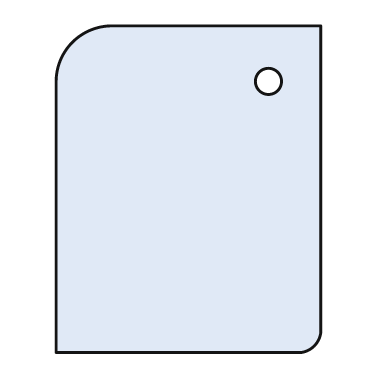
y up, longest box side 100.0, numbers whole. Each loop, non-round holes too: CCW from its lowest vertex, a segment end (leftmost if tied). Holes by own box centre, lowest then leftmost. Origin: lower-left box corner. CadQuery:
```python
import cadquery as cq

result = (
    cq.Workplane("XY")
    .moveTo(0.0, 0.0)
    .lineTo(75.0, 0.0)
    .threePointArc((79.0, 2.0), (81.0, 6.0))
    .lineTo(81.0, 100.0)
    .lineTo(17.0, 100.0)
    .threePointArc((5.0, 95.0), (0.0, 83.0))
    .close()
    .moveTo(65.0, 83.0)
    .circle(4.0)
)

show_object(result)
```